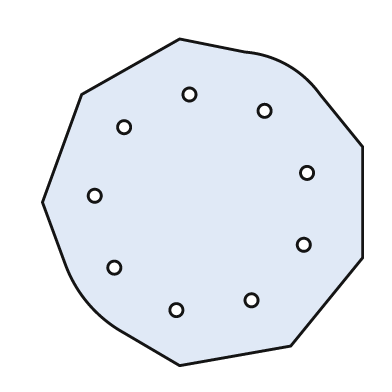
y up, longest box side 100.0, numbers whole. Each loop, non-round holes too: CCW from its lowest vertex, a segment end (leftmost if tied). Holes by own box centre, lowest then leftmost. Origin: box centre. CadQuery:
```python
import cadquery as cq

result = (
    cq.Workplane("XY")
    .moveTo(-7.0, -50.0)
    .lineTo(27.0, -44.0)
    .lineTo(49.0, -17.0)
    .lineTo(49.0, 17.0)
    .lineTo(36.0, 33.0)
    .threePointArc((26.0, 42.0), (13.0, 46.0))
    .lineTo(-7.0, 50.0)
    .lineTo(-37.0, 33.0)
    .lineTo(-49.0, 0.0)
    .lineTo(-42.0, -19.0)
    .threePointArc((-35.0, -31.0), (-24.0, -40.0))
    .close()
    .moveTo(-8.0, -33.0)
    .circle(2.0)
    .moveTo(15.0, -30.0)
    .circle(2.0)
    .moveTo(-27.0, -20.0)
    .circle(2.0)
    .moveTo(31.0, -13.0)
    .circle(2.0)
    .moveTo(-33.0, 2.0)
    .circle(2.0)
    .moveTo(32.0, 9.0)
    .circle(2.0)
    .moveTo(-24.0, 23.0)
    .circle(2.0)
    .moveTo(19.0, 28.0)
    .circle(2.0)
    .moveTo(-4.0, 33.0)
    .circle(2.0)
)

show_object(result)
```